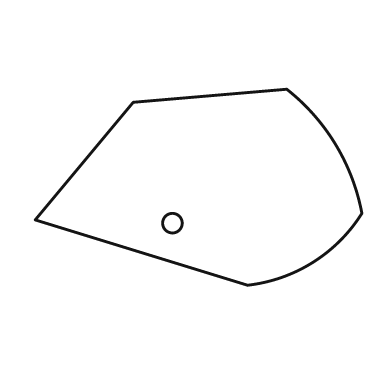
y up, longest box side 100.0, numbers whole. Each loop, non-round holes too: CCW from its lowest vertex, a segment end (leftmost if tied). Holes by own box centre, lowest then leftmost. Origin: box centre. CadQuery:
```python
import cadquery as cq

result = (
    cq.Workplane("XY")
    .moveTo(15.0, -30.0)
    .threePointArc((35.0, -23.0), (50.0, -8.0))
    .threePointArc((42.0, 13.0), (27.0, 30.0))
    .lineTo(-20.0, 26.0)
    .lineTo(-50.0, -10.0)
    .close()
    .moveTo(-8.0, -11.0)
    .circle(3.0)
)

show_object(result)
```